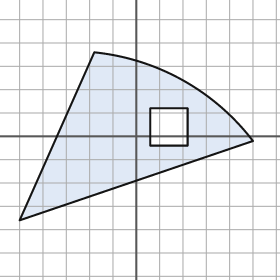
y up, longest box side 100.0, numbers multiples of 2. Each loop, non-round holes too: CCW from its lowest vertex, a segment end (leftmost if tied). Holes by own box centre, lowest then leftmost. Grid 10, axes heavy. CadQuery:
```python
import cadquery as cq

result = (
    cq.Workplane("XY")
    .moveTo(-50.0, -36.0)
    .lineTo(50.0, -2.0)
    .threePointArc((20.0, 24.0), (-18.0, 36.0))
    .close()
    .moveTo(6.0, -4.0)
    .lineTo(22.0, -4.0)
    .lineTo(22.0, 12.0)
    .lineTo(6.0, 12.0)
    .close()
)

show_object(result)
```